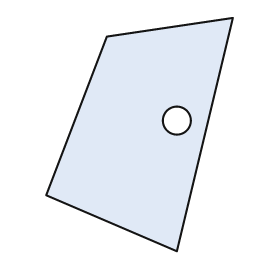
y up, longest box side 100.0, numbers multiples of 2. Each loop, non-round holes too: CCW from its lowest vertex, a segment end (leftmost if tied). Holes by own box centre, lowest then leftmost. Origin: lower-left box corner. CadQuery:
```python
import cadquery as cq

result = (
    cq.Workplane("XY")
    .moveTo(56.0, 0.0)
    .lineTo(80.0, 100.0)
    .lineTo(26.0, 92.0)
    .lineTo(0.0, 24.0)
    .close()
    .moveTo(56.0, 56.0)
    .circle(6.0)
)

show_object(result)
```